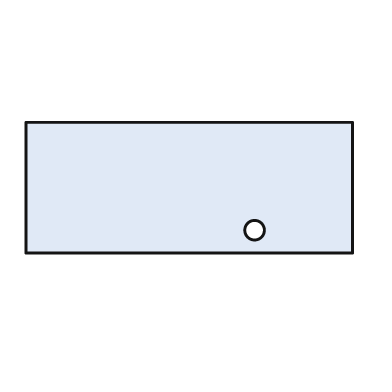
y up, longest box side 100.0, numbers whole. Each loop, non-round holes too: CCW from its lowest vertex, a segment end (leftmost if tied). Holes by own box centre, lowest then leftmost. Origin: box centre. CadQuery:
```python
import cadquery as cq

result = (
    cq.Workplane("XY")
    .moveTo(-50.0, -20.0)
    .lineTo(50.0, -20.0)
    .lineTo(50.0, 20.0)
    .lineTo(-50.0, 20.0)
    .close()
    .moveTo(20.0, -13.0)
    .circle(3.0)
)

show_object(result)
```